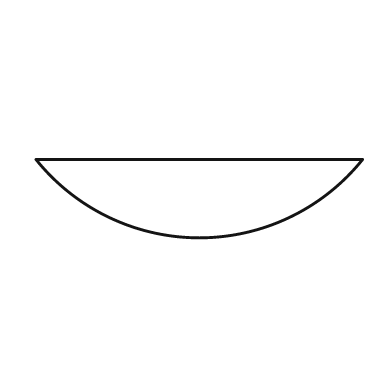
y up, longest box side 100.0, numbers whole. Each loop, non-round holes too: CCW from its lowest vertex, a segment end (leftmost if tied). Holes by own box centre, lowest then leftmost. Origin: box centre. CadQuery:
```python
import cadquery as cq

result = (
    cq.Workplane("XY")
    .moveTo(-50.0, 12.0)
    .threePointArc((0.0, -12.0), (50.0, 12.0))
    .close()
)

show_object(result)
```